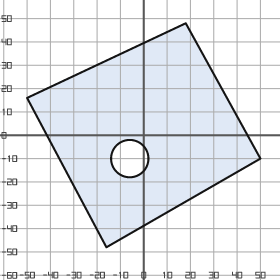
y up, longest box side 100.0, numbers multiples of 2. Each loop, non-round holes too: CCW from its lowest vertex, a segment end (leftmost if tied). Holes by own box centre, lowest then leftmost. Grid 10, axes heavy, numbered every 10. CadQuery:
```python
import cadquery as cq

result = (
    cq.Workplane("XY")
    .moveTo(-16.0, -48.0)
    .lineTo(50.0, -10.0)
    .lineTo(18.0, 48.0)
    .lineTo(-50.0, 16.0)
    .close()
    .moveTo(-6.0, -10.0)
    .circle(8.0)
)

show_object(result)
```